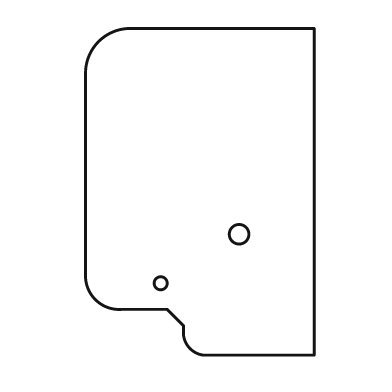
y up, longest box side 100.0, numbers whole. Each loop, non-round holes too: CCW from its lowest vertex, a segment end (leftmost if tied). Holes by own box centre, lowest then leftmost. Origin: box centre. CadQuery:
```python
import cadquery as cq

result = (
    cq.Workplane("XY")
    .moveTo(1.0, -50.0)
    .lineTo(35.0, -50.0)
    .lineTo(35.0, 50.0)
    .lineTo(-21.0, 50.0)
    .threePointArc((-31.0, 46.0), (-35.0, 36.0))
    .lineTo(-35.0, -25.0)
    .threePointArc((-32.0, -33.0), (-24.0, -36.0))
    .lineTo(-10.0, -36.0)
    .lineTo(-5.0, -41.0)
    .lineTo(-5.0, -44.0)
    .threePointArc((-3.0, -48.0), (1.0, -50.0))
    .close()
    .moveTo(-12.0, -28.0)
    .circle(2.0)
    .moveTo(12.0, -13.0)
    .circle(3.0)
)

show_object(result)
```